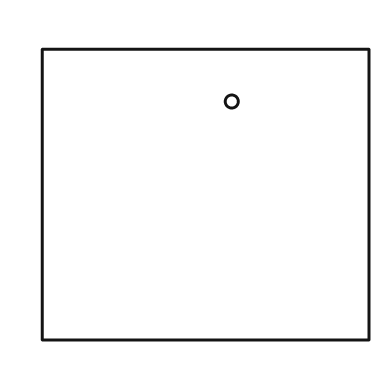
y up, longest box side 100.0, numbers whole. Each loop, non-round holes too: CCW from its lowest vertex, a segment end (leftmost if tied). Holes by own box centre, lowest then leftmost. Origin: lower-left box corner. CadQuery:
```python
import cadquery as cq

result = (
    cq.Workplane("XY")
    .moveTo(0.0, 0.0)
    .lineTo(100.0, 0.0)
    .lineTo(100.0, 89.0)
    .lineTo(0.0, 89.0)
    .close()
    .moveTo(58.0, 73.0)
    .circle(2.0)
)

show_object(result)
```